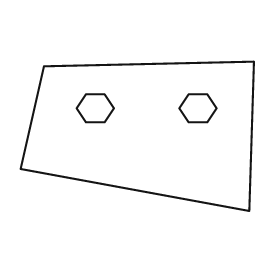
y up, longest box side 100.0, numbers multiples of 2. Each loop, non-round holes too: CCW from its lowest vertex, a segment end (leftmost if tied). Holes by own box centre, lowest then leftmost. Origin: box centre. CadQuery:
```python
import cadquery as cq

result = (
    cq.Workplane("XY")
    .moveTo(48.0, -32.0)
    .lineTo(50.0, 32.0)
    .lineTo(-40.0, 30.0)
    .lineTo(-50.0, -14.0)
    .close()
    .moveTo(-22.0, 6.0)
    .lineTo(-14.0, 6.0)
    .lineTo(-10.0, 12.0)
    .lineTo(-14.0, 18.0)
    .lineTo(-22.0, 18.0)
    .lineTo(-26.0, 12.0)
    .close()
    .moveTo(22.0, 6.0)
    .lineTo(30.0, 6.0)
    .lineTo(34.0, 12.0)
    .lineTo(30.0, 18.0)
    .lineTo(22.0, 18.0)
    .lineTo(18.0, 12.0)
    .close()
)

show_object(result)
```